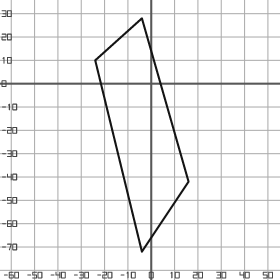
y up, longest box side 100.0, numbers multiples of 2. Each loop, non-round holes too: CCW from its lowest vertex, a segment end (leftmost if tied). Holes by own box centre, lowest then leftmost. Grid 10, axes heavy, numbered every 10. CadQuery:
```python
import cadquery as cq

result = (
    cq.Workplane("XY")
    .moveTo(-4.0, -72.0)
    .lineTo(16.0, -42.0)
    .lineTo(-4.0, 28.0)
    .lineTo(-24.0, 10.0)
    .close()
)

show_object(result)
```